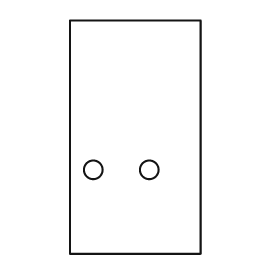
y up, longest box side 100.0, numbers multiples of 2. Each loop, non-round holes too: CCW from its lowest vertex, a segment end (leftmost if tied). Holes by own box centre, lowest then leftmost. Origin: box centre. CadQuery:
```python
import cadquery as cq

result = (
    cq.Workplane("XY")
    .moveTo(-28.0, -50.0)
    .lineTo(28.0, -50.0)
    .lineTo(28.0, 50.0)
    .lineTo(-28.0, 50.0)
    .close()
    .moveTo(-18.0, -14.0)
    .circle(4.0)
    .moveTo(6.0, -14.0)
    .circle(4.0)
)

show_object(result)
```